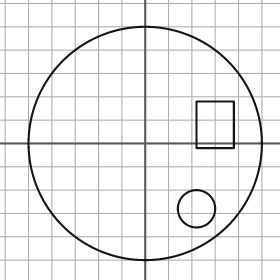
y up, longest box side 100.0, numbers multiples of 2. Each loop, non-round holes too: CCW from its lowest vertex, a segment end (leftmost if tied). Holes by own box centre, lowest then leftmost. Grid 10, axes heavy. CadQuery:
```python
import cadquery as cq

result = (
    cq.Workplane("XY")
    .moveTo(0.0, 0.0)
    .circle(50.0)
    .moveTo(22.0, -28.0)
    .circle(8.0)
    .moveTo(22.0, -2.0)
    .lineTo(38.0, -2.0)
    .lineTo(38.0, 18.0)
    .lineTo(22.0, 18.0)
    .close()
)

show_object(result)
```